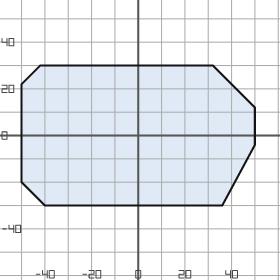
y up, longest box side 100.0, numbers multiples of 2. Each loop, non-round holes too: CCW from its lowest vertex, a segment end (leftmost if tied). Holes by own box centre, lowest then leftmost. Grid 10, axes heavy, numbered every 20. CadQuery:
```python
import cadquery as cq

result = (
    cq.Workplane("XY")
    .moveTo(-40.0, -30.0)
    .lineTo(36.0, -30.0)
    .lineTo(50.0, -4.0)
    .lineTo(50.0, 12.0)
    .lineTo(32.0, 30.0)
    .lineTo(-42.0, 30.0)
    .lineTo(-50.0, 22.0)
    .lineTo(-50.0, -20.0)
    .close()
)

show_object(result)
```